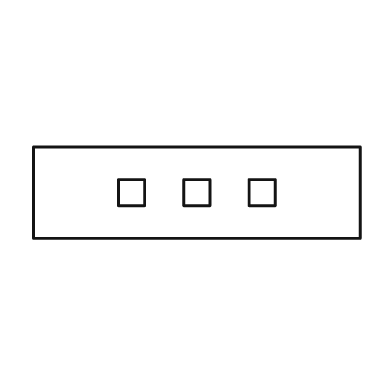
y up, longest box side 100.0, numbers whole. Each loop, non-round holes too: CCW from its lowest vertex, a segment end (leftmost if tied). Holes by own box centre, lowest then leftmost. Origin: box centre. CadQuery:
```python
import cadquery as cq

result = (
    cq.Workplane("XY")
    .moveTo(-50.0, -14.0)
    .lineTo(50.0, -14.0)
    .lineTo(50.0, 14.0)
    .lineTo(-50.0, 14.0)
    .close()
    .moveTo(-24.0, -4.0)
    .lineTo(-16.0, -4.0)
    .lineTo(-16.0, 4.0)
    .lineTo(-24.0, 4.0)
    .close()
    .moveTo(-4.0, -4.0)
    .lineTo(4.0, -4.0)
    .lineTo(4.0, 4.0)
    .lineTo(-4.0, 4.0)
    .close()
    .moveTo(16.0, -4.0)
    .lineTo(24.0, -4.0)
    .lineTo(24.0, 4.0)
    .lineTo(16.0, 4.0)
    .close()
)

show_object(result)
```